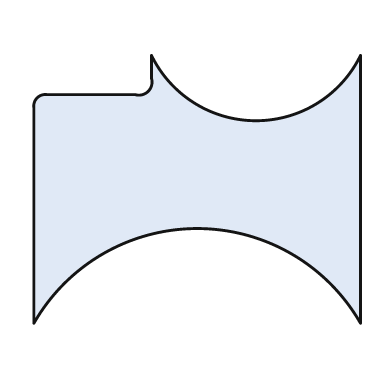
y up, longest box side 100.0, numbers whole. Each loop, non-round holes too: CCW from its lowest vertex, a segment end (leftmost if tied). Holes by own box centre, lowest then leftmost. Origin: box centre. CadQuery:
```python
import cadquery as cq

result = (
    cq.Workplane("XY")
    .moveTo(-50.0, -41.0)
    .threePointArc((0.0, -12.0), (50.0, -41.0))
    .lineTo(50.0, 41.0)
    .threePointArc((18.0, 21.0), (-14.0, 41.0))
    .lineTo(-14.0, 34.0)
    .threePointArc((-15.0, 30.0), (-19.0, 29.0))
    .lineTo(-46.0, 29.0)
    .threePointArc((-49.0, 28.0), (-50.0, 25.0))
    .close()
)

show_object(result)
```